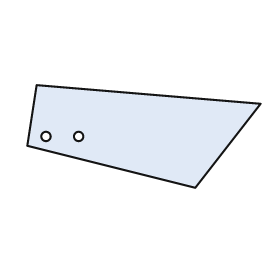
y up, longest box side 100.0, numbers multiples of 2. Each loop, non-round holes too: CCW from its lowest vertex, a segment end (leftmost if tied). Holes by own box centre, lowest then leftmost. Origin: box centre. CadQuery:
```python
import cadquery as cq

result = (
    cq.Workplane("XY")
    .moveTo(22.0, -22.0)
    .lineTo(50.0, 14.0)
    .lineTo(-46.0, 22.0)
    .lineTo(-50.0, -4.0)
    .close()
    .moveTo(-42.0, 0.0)
    .circle(2.0)
    .moveTo(-28.0, 0.0)
    .circle(2.0)
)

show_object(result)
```